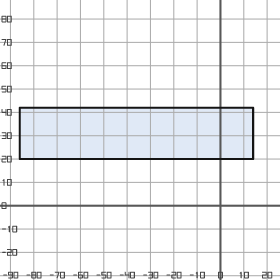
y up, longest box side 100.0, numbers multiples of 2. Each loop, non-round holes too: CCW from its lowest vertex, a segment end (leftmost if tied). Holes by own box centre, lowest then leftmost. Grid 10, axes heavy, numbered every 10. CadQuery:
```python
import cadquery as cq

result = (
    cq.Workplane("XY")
    .moveTo(-86.0, 20.0)
    .lineTo(14.0, 20.0)
    .lineTo(14.0, 42.0)
    .lineTo(-86.0, 42.0)
    .close()
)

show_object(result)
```